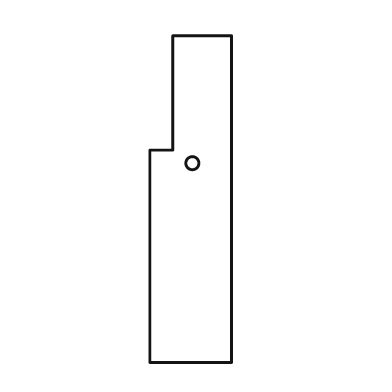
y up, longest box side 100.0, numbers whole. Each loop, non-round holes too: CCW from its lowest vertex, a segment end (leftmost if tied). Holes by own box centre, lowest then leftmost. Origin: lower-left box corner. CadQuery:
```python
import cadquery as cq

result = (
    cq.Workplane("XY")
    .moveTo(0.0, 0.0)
    .lineTo(25.0, 0.0)
    .lineTo(25.0, 100.0)
    .lineTo(7.0, 100.0)
    .lineTo(7.0, 65.0)
    .lineTo(0.0, 65.0)
    .close()
    .moveTo(13.0, 61.0)
    .circle(2.0)
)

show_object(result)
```